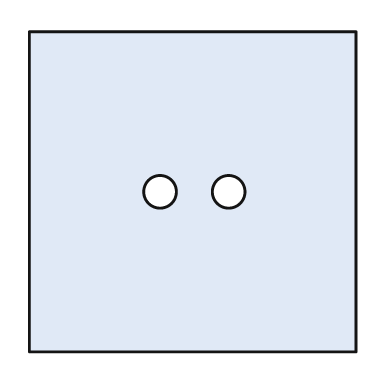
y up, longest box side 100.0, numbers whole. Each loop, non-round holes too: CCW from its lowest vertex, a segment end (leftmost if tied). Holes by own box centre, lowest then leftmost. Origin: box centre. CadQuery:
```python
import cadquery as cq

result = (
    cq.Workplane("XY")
    .moveTo(-50.0, -49.0)
    .lineTo(50.0, -49.0)
    .lineTo(50.0, 49.0)
    .lineTo(-50.0, 49.0)
    .close()
    .moveTo(-10.0, 0.0)
    .circle(5.0)
    .moveTo(11.0, 0.0)
    .circle(5.0)
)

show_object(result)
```